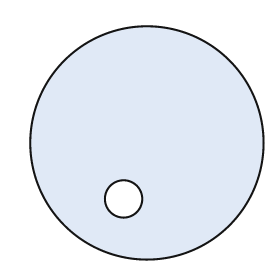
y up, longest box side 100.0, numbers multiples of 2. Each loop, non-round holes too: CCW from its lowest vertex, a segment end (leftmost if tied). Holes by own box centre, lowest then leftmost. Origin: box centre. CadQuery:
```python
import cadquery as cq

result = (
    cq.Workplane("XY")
    .moveTo(0.0, 0.0)
    .circle(50.0)
    .moveTo(-10.0, -24.0)
    .circle(8.0)
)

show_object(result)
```